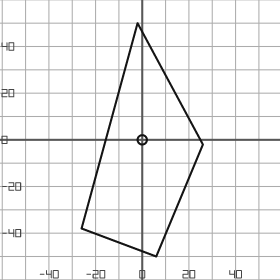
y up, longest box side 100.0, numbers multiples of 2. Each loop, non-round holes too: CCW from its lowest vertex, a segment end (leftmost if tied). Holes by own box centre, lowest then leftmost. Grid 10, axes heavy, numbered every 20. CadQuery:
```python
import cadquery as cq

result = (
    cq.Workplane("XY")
    .moveTo(6.0, -50.0)
    .lineTo(26.0, -2.0)
    .lineTo(-2.0, 50.0)
    .lineTo(-26.0, -38.0)
    .close()
    .moveTo(0.0, 0.0)
    .circle(2.0)
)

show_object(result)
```